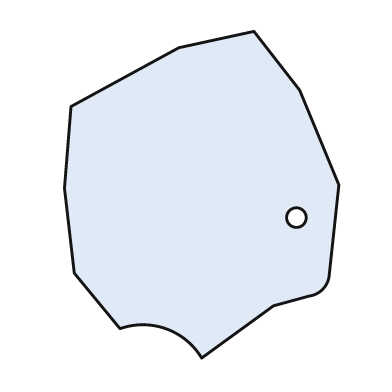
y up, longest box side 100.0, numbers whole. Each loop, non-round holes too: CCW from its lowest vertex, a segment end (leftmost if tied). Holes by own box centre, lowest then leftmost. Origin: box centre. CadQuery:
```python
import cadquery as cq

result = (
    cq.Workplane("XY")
    .moveTo(0.0, -50.0)
    .lineTo(22.0, -34.0)
    .lineTo(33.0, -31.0)
    .threePointArc((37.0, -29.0), (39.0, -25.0))
    .lineTo(42.0, 3.0)
    .lineTo(30.0, 32.0)
    .lineTo(16.0, 50.0)
    .lineTo(-7.0, 45.0)
    .lineTo(-40.0, 27.0)
    .lineTo(-42.0, 2.0)
    .lineTo(-39.0, -24.0)
    .lineTo(-25.0, -41.0)
    .threePointArc((-11.0, -41.0), (0.0, -50.0))
    .close()
    .moveTo(29.0, -7.0)
    .circle(3.0)
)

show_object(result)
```